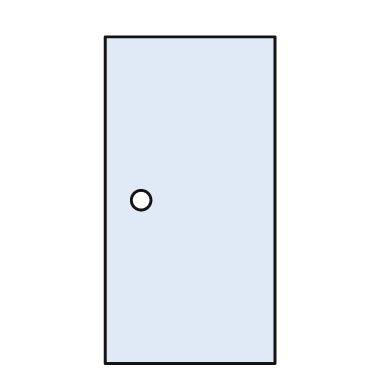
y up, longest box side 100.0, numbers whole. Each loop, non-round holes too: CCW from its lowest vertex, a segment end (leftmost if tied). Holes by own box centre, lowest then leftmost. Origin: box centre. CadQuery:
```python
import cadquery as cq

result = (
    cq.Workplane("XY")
    .moveTo(-26.0, -50.0)
    .lineTo(26.0, -50.0)
    .lineTo(26.0, 50.0)
    .lineTo(-26.0, 50.0)
    .close()
    .moveTo(-15.0, 0.0)
    .circle(3.0)
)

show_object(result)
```